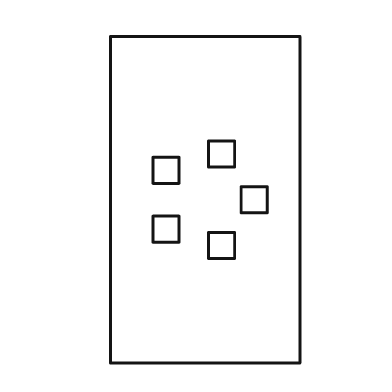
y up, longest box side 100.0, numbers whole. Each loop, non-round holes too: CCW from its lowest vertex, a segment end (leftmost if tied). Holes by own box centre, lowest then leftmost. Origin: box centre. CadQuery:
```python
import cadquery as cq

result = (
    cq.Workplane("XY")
    .moveTo(-29.0, -50.0)
    .lineTo(29.0, -50.0)
    .lineTo(29.0, 50.0)
    .lineTo(-29.0, 50.0)
    .close()
    .moveTo(1.0, -18.0)
    .lineTo(9.0, -18.0)
    .lineTo(9.0, -10.0)
    .lineTo(1.0, -10.0)
    .close()
    .moveTo(-16.0, -13.0)
    .lineTo(-8.0, -13.0)
    .lineTo(-8.0, -5.0)
    .lineTo(-16.0, -5.0)
    .close()
    .moveTo(11.0, -4.0)
    .lineTo(19.0, -4.0)
    .lineTo(19.0, 4.0)
    .lineTo(11.0, 4.0)
    .close()
    .moveTo(-16.0, 5.0)
    .lineTo(-8.0, 5.0)
    .lineTo(-8.0, 13.0)
    .lineTo(-16.0, 13.0)
    .close()
    .moveTo(1.0, 10.0)
    .lineTo(9.0, 10.0)
    .lineTo(9.0, 18.0)
    .lineTo(1.0, 18.0)
    .close()
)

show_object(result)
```